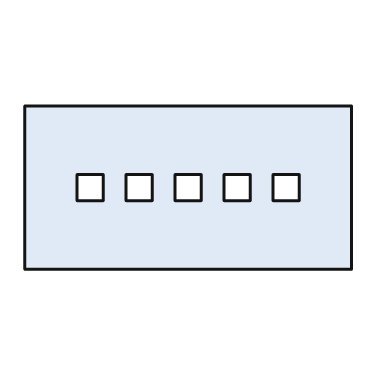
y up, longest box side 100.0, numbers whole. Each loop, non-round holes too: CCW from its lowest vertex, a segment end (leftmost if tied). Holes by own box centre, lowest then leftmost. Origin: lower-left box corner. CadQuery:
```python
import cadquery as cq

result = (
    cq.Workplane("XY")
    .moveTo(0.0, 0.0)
    .lineTo(100.0, 0.0)
    .lineTo(100.0, 50.0)
    .lineTo(0.0, 50.0)
    .close()
    .moveTo(16.0, 21.0)
    .lineTo(24.0, 21.0)
    .lineTo(24.0, 29.0)
    .lineTo(16.0, 29.0)
    .close()
    .moveTo(31.0, 21.0)
    .lineTo(39.0, 21.0)
    .lineTo(39.0, 29.0)
    .lineTo(31.0, 29.0)
    .close()
    .moveTo(46.0, 21.0)
    .lineTo(54.0, 21.0)
    .lineTo(54.0, 29.0)
    .lineTo(46.0, 29.0)
    .close()
    .moveTo(61.0, 21.0)
    .lineTo(69.0, 21.0)
    .lineTo(69.0, 29.0)
    .lineTo(61.0, 29.0)
    .close()
    .moveTo(76.0, 21.0)
    .lineTo(84.0, 21.0)
    .lineTo(84.0, 29.0)
    .lineTo(76.0, 29.0)
    .close()
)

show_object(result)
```